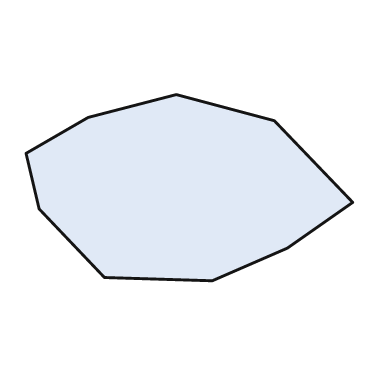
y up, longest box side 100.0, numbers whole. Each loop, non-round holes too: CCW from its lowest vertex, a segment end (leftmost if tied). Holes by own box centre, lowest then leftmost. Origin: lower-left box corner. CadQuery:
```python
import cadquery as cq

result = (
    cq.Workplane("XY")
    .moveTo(57.0, 0.0)
    .lineTo(80.0, 10.0)
    .lineTo(100.0, 24.0)
    .lineTo(76.0, 49.0)
    .lineTo(46.0, 57.0)
    .lineTo(19.0, 50.0)
    .lineTo(0.0, 39.0)
    .lineTo(4.0, 22.0)
    .lineTo(24.0, 1.0)
    .close()
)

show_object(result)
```